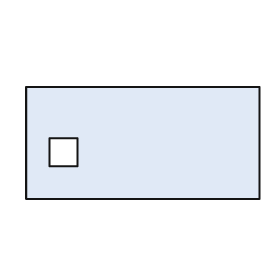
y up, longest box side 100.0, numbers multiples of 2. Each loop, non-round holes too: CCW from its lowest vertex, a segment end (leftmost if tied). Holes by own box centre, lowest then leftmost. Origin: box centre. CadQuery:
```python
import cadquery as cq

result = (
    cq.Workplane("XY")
    .moveTo(-50.0, -24.0)
    .lineTo(50.0, -24.0)
    .lineTo(50.0, 24.0)
    .lineTo(-50.0, 24.0)
    .close()
    .moveTo(-40.0, -10.0)
    .lineTo(-28.0, -10.0)
    .lineTo(-28.0, 2.0)
    .lineTo(-40.0, 2.0)
    .close()
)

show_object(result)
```